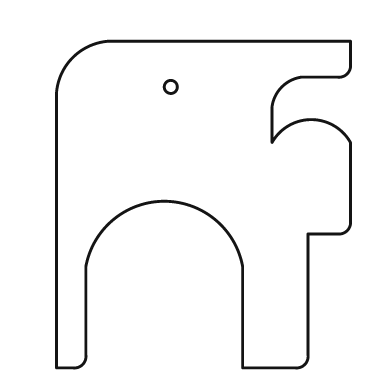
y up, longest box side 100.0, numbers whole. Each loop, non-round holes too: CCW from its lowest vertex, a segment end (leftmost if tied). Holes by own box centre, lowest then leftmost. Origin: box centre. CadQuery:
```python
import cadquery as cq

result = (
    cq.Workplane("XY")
    .moveTo(-45.0, -50.0)
    .lineTo(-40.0, -50.0)
    .threePointArc((-37.0, -49.0), (-36.0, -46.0))
    .lineTo(-36.0, -19.0)
    .threePointArc((-12.0, 1.0), (12.0, -19.0))
    .lineTo(12.0, -50.0)
    .lineTo(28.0, -50.0)
    .threePointArc((31.0, -49.0), (32.0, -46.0))
    .lineTo(32.0, -9.0)
    .lineTo(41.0, -9.0)
    .threePointArc((44.0, -8.0), (45.0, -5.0))
    .lineTo(45.0, 19.0)
    .threePointArc((33.0, 26.0), (21.0, 19.0))
    .lineTo(21.0, 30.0)
    .threePointArc((24.0, 36.0), (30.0, 39.0))
    .lineTo(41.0, 39.0)
    .threePointArc((44.0, 40.0), (45.0, 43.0))
    .lineTo(45.0, 50.0)
    .lineTo(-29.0, 50.0)
    .threePointArc((-40.0, 45.0), (-45.0, 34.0))
    .close()
    .moveTo(-10.0, 36.0)
    .circle(2.0)
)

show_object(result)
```